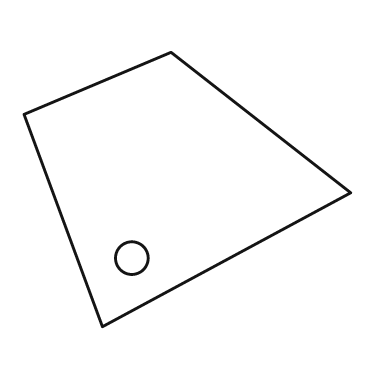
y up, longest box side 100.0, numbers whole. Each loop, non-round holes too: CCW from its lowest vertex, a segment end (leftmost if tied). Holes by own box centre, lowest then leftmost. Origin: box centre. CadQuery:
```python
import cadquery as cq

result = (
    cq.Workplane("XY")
    .moveTo(-26.0, -42.0)
    .lineTo(50.0, -1.0)
    .lineTo(-5.0, 42.0)
    .lineTo(-50.0, 23.0)
    .close()
    .moveTo(-17.0, -21.0)
    .circle(5.0)
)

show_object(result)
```